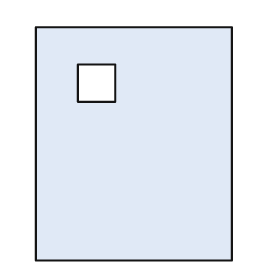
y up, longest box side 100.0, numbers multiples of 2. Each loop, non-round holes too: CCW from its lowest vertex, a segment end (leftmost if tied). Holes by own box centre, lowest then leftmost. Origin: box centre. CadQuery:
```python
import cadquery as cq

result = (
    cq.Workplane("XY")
    .moveTo(-42.0, -50.0)
    .lineTo(42.0, -50.0)
    .lineTo(42.0, 50.0)
    .lineTo(-42.0, 50.0)
    .close()
    .moveTo(-24.0, 18.0)
    .lineTo(-8.0, 18.0)
    .lineTo(-8.0, 34.0)
    .lineTo(-24.0, 34.0)
    .close()
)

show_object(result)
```